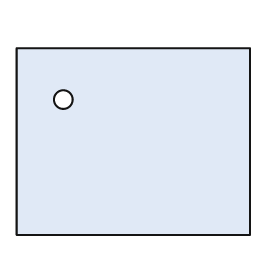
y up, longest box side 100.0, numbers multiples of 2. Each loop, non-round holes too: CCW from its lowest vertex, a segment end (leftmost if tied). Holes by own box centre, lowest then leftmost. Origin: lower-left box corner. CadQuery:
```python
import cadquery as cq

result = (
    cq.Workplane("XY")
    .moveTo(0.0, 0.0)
    .lineTo(100.0, 0.0)
    .lineTo(100.0, 80.0)
    .lineTo(0.0, 80.0)
    .close()
    .moveTo(20.0, 58.0)
    .circle(4.0)
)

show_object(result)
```